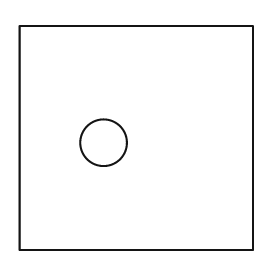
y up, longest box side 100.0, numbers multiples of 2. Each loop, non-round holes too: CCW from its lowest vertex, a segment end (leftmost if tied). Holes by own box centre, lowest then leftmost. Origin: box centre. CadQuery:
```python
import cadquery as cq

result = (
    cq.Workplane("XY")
    .moveTo(-50.0, -48.0)
    .lineTo(50.0, -48.0)
    .lineTo(50.0, 48.0)
    .lineTo(-50.0, 48.0)
    .close()
    .moveTo(-14.0, -2.0)
    .circle(10.0)
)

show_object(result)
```